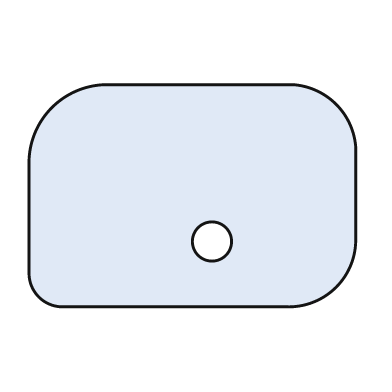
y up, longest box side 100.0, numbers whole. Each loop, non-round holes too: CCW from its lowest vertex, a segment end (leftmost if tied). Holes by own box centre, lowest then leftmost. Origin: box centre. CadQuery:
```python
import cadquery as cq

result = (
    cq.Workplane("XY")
    .moveTo(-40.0, -34.0)
    .lineTo(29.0, -34.0)
    .threePointArc((44.0, -28.0), (50.0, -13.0))
    .lineTo(50.0, 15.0)
    .threePointArc((44.0, 28.0), (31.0, 34.0))
    .lineTo(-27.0, 34.0)
    .threePointArc((-43.0, 27.0), (-50.0, 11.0))
    .lineTo(-50.0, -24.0)
    .threePointArc((-47.0, -31.0), (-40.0, -34.0))
    .close()
    .moveTo(6.0, -14.0)
    .circle(6.0)
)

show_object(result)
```